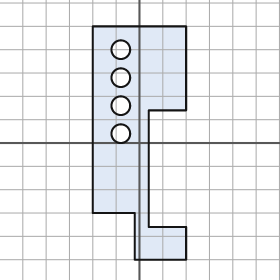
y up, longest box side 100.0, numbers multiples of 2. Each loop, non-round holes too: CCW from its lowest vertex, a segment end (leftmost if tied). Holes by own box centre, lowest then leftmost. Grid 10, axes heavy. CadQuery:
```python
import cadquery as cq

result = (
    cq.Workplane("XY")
    .moveTo(-2.0, -50.0)
    .lineTo(20.0, -50.0)
    .lineTo(20.0, -36.0)
    .lineTo(4.0, -36.0)
    .lineTo(4.0, 14.0)
    .lineTo(20.0, 14.0)
    .lineTo(20.0, 50.0)
    .lineTo(-20.0, 50.0)
    .lineTo(-20.0, -30.0)
    .lineTo(-2.0, -30.0)
    .close()
    .moveTo(-8.0, 4.0)
    .circle(4.0)
    .moveTo(-8.0, 16.0)
    .circle(4.0)
    .moveTo(-8.0, 28.0)
    .circle(4.0)
    .moveTo(-8.0, 40.0)
    .circle(4.0)
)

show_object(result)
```